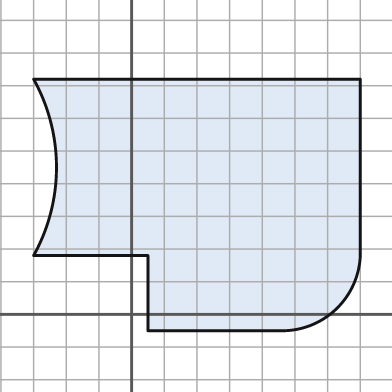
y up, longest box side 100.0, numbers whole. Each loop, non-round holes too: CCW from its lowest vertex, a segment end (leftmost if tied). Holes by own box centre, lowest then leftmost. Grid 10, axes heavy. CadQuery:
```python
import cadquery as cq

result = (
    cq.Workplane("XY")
    .moveTo(5.0, -5.0)
    .lineTo(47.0, -5.0)
    .threePointArc((63.0, 2.0), (70.0, 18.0))
    .lineTo(70.0, 72.0)
    .lineTo(-30.0, 72.0)
    .threePointArc((-23.0, 45.0), (-30.0, 18.0))
    .lineTo(5.0, 18.0)
    .close()
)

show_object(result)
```